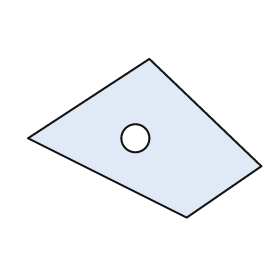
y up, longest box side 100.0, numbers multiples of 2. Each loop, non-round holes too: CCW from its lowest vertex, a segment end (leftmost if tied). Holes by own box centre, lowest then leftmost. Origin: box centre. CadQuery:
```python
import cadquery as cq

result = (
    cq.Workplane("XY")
    .moveTo(18.0, -34.0)
    .lineTo(50.0, -12.0)
    .lineTo(2.0, 34.0)
    .lineTo(-50.0, 0.0)
    .close()
    .moveTo(-4.0, 0.0)
    .circle(6.0)
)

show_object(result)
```